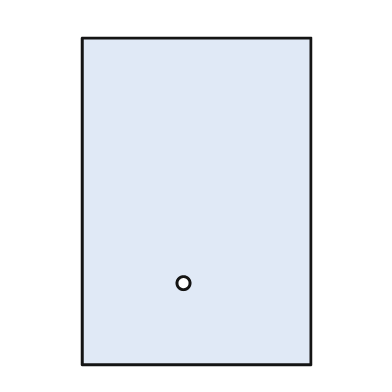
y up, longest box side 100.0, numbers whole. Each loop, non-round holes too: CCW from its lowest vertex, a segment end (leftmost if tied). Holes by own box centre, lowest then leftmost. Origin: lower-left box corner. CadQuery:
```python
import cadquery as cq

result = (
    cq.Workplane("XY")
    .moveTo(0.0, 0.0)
    .lineTo(70.0, 0.0)
    .lineTo(70.0, 100.0)
    .lineTo(0.0, 100.0)
    .close()
    .moveTo(31.0, 25.0)
    .circle(2.0)
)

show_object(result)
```